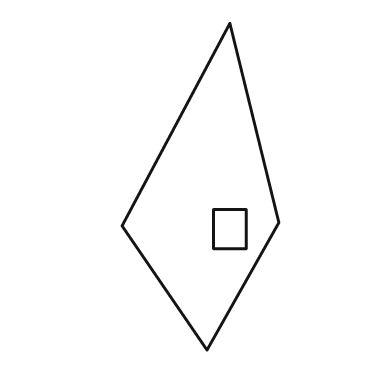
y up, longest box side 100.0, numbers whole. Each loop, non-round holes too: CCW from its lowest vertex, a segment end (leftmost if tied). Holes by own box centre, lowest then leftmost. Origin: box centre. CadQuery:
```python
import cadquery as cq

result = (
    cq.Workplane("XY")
    .moveTo(2.0, -50.0)
    .lineTo(24.0, -11.0)
    .lineTo(9.0, 50.0)
    .lineTo(-24.0, -12.0)
    .close()
    .moveTo(4.0, -19.0)
    .lineTo(14.0, -19.0)
    .lineTo(14.0, -7.0)
    .lineTo(4.0, -7.0)
    .close()
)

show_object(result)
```